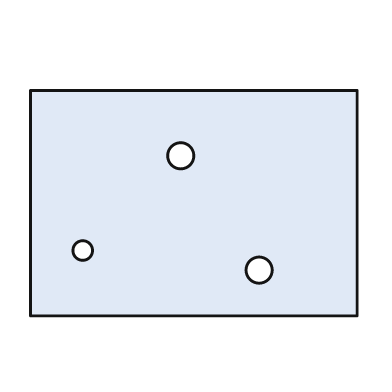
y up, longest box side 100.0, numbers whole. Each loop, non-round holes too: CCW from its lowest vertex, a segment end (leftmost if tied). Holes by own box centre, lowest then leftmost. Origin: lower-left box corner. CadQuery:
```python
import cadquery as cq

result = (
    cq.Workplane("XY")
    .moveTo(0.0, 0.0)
    .lineTo(100.0, 0.0)
    .lineTo(100.0, 69.0)
    .lineTo(0.0, 69.0)
    .close()
    .moveTo(70.0, 14.0)
    .circle(4.0)
    .moveTo(16.0, 20.0)
    .circle(3.0)
    .moveTo(46.0, 49.0)
    .circle(4.0)
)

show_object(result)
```